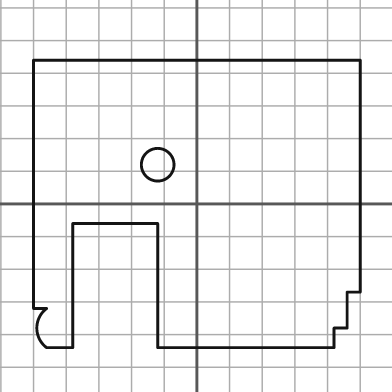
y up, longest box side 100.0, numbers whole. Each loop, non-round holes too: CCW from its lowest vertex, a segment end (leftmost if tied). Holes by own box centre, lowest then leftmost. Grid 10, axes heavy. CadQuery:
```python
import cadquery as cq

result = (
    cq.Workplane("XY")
    .moveTo(-46.0, -44.0)
    .lineTo(-38.0, -44.0)
    .lineTo(-38.0, -6.0)
    .lineTo(-12.0, -6.0)
    .lineTo(-12.0, -44.0)
    .lineTo(42.0, -44.0)
    .lineTo(42.0, -38.0)
    .lineTo(46.0, -38.0)
    .lineTo(46.0, -27.0)
    .lineTo(50.0, -27.0)
    .lineTo(50.0, 44.0)
    .lineTo(-50.0, 44.0)
    .lineTo(-50.0, -32.0)
    .lineTo(-46.0, -32.0)
    .threePointArc((-49.0, -38.0), (-46.0, -44.0))
    .close()
    .moveTo(-12.0, 12.0)
    .circle(5.0)
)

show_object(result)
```